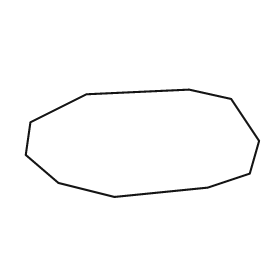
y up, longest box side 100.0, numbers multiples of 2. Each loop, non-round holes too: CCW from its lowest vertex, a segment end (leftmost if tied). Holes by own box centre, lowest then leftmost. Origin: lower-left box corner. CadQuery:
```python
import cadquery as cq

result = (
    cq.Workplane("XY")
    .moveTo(38.0, 0.0)
    .lineTo(78.0, 4.0)
    .lineTo(96.0, 10.0)
    .lineTo(100.0, 24.0)
    .lineTo(88.0, 42.0)
    .lineTo(70.0, 46.0)
    .lineTo(26.0, 44.0)
    .lineTo(2.0, 32.0)
    .lineTo(0.0, 18.0)
    .lineTo(14.0, 6.0)
    .close()
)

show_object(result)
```